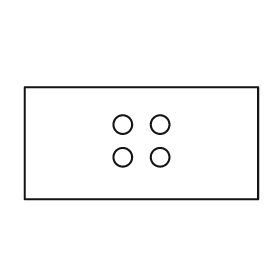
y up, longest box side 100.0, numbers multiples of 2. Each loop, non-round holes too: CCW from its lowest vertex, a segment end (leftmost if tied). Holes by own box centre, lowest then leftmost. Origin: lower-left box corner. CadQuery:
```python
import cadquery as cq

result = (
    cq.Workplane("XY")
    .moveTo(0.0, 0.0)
    .lineTo(100.0, 0.0)
    .lineTo(100.0, 48.0)
    .lineTo(0.0, 48.0)
    .close()
    .moveTo(42.0, 18.0)
    .circle(4.0)
    .moveTo(58.0, 18.0)
    .circle(4.0)
    .moveTo(42.0, 32.0)
    .circle(4.0)
    .moveTo(58.0, 32.0)
    .circle(4.0)
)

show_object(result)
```